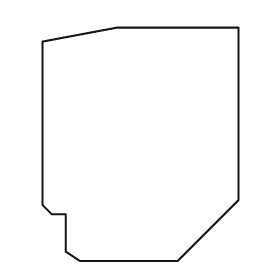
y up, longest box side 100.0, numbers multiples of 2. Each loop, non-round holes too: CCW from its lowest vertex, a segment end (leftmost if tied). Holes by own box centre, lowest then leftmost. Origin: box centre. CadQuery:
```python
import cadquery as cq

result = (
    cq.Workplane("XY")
    .moveTo(-26.0, -50.0)
    .lineTo(16.0, -50.0)
    .lineTo(42.0, -24.0)
    .lineTo(42.0, 50.0)
    .lineTo(-10.0, 50.0)
    .lineTo(-42.0, 44.0)
    .lineTo(-42.0, -26.0)
    .lineTo(-38.0, -30.0)
    .lineTo(-32.0, -30.0)
    .lineTo(-32.0, -46.0)
    .close()
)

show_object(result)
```